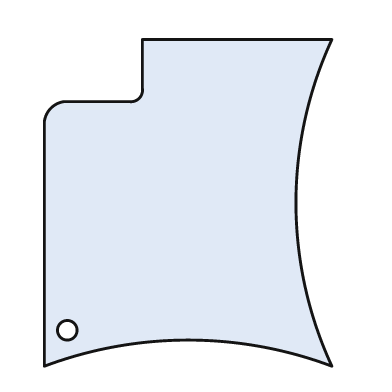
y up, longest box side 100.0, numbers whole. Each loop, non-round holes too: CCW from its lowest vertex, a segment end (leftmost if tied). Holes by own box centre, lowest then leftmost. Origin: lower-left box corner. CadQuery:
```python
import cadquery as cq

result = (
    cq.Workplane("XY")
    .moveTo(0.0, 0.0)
    .threePointArc((44.0, 8.0), (88.0, 0.0))
    .threePointArc((77.0, 50.0), (88.0, 100.0))
    .lineTo(30.0, 100.0)
    .lineTo(30.0, 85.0)
    .threePointArc((29.0, 82.0), (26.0, 81.0))
    .lineTo(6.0, 81.0)
    .threePointArc((2.0, 79.0), (0.0, 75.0))
    .close()
    .moveTo(7.0, 11.0)
    .circle(3.0)
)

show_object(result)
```